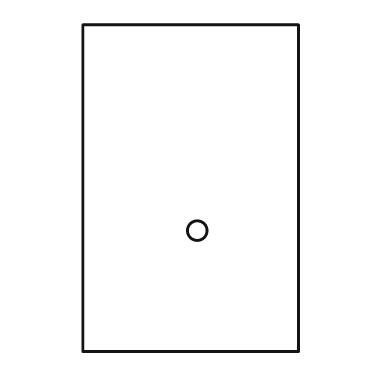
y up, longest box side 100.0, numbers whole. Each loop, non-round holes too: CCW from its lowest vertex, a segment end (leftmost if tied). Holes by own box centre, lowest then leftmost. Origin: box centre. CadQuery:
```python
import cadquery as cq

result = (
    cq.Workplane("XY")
    .moveTo(-33.0, -50.0)
    .lineTo(33.0, -50.0)
    .lineTo(33.0, 50.0)
    .lineTo(-33.0, 50.0)
    .close()
    .moveTo(2.0, -13.0)
    .circle(3.0)
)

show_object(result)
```